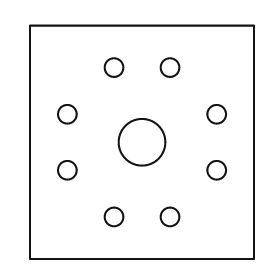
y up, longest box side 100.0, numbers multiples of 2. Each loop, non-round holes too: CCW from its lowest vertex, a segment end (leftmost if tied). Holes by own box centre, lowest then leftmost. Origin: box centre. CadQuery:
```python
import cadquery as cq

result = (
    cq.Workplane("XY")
    .moveTo(-48.0, -50.0)
    .lineTo(48.0, -50.0)
    .lineTo(48.0, 50.0)
    .lineTo(-48.0, 50.0)
    .close()
    .moveTo(-12.0, -32.0)
    .circle(4.0)
    .moveTo(12.0, -32.0)
    .circle(4.0)
    .moveTo(-32.0, -12.0)
    .circle(4.0)
    .moveTo(32.0, -12.0)
    .circle(4.0)
    .moveTo(0.0, 0.0)
    .circle(10.0)
    .moveTo(-32.0, 12.0)
    .circle(4.0)
    .moveTo(32.0, 12.0)
    .circle(4.0)
    .moveTo(-12.0, 32.0)
    .circle(4.0)
    .moveTo(12.0, 32.0)
    .circle(4.0)
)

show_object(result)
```